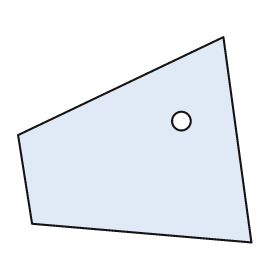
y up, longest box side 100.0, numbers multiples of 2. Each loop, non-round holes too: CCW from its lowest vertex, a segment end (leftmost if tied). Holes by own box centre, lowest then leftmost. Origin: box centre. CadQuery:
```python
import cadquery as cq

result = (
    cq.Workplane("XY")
    .moveTo(50.0, -44.0)
    .lineTo(38.0, 44.0)
    .lineTo(-50.0, 2.0)
    .lineTo(-44.0, -36.0)
    .close()
    .moveTo(20.0, 8.0)
    .circle(4.0)
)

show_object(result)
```